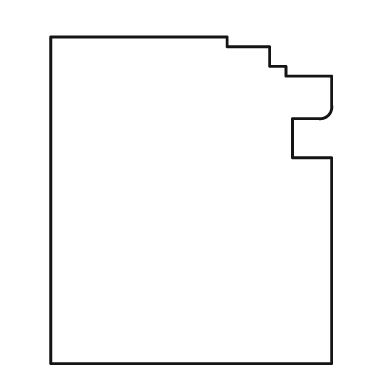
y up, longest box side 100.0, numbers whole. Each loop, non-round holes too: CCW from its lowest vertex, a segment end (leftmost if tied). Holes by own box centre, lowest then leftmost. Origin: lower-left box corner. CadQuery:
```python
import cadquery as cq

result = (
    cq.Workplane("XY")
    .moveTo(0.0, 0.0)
    .lineTo(86.0, 0.0)
    .lineTo(86.0, 63.0)
    .lineTo(74.0, 63.0)
    .lineTo(74.0, 75.0)
    .lineTo(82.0, 75.0)
    .threePointArc((85.0, 76.0), (86.0, 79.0))
    .lineTo(86.0, 88.0)
    .lineTo(72.0, 88.0)
    .lineTo(72.0, 91.0)
    .lineTo(67.0, 91.0)
    .lineTo(67.0, 97.0)
    .lineTo(54.0, 97.0)
    .lineTo(54.0, 100.0)
    .lineTo(0.0, 100.0)
    .close()
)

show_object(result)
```